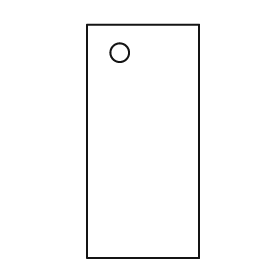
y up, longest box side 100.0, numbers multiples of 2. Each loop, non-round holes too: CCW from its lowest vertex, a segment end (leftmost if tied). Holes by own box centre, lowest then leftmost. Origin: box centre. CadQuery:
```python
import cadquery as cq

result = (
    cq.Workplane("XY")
    .moveTo(-24.0, -50.0)
    .lineTo(24.0, -50.0)
    .lineTo(24.0, 50.0)
    .lineTo(-24.0, 50.0)
    .close()
    .moveTo(-10.0, 38.0)
    .circle(4.0)
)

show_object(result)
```